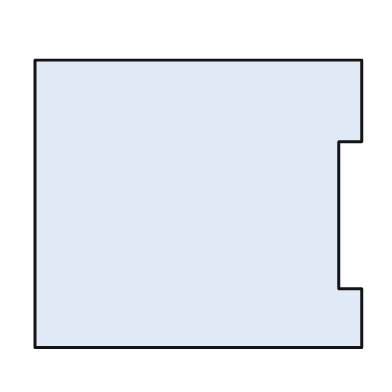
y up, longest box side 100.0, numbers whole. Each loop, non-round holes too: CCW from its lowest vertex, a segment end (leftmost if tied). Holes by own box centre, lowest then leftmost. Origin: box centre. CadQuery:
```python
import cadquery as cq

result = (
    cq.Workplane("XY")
    .moveTo(-50.0, -44.0)
    .lineTo(50.0, -44.0)
    .lineTo(50.0, -26.0)
    .lineTo(43.0, -26.0)
    .lineTo(43.0, 19.0)
    .lineTo(50.0, 19.0)
    .lineTo(50.0, 44.0)
    .lineTo(-50.0, 44.0)
    .close()
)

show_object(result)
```